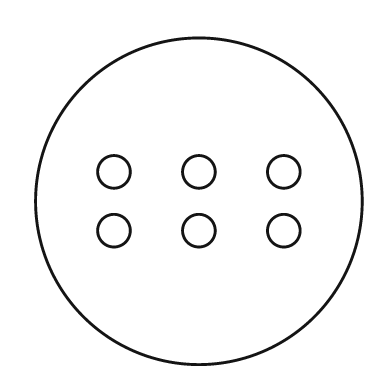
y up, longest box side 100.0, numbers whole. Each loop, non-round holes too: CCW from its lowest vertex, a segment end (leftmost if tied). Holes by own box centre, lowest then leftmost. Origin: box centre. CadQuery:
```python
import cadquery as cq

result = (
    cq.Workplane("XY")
    .moveTo(0.0, 0.0)
    .circle(50.0)
    .moveTo(-26.0, -9.0)
    .circle(5.0)
    .moveTo(0.0, -9.0)
    .circle(5.0)
    .moveTo(26.0, -9.0)
    .circle(5.0)
    .moveTo(-26.0, 9.0)
    .circle(5.0)
    .moveTo(0.0, 9.0)
    .circle(5.0)
    .moveTo(26.0, 9.0)
    .circle(5.0)
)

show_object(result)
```